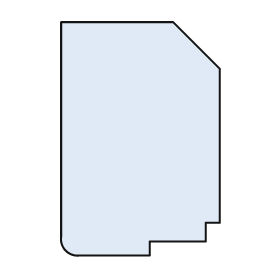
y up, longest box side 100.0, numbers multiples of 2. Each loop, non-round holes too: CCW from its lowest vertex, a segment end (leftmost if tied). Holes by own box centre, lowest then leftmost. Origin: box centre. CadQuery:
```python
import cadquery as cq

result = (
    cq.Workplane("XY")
    .moveTo(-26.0, -50.0)
    .lineTo(4.0, -50.0)
    .lineTo(4.0, -44.0)
    .lineTo(28.0, -44.0)
    .lineTo(28.0, -36.0)
    .lineTo(34.0, -36.0)
    .lineTo(34.0, 30.0)
    .lineTo(14.0, 50.0)
    .lineTo(-34.0, 50.0)
    .lineTo(-34.0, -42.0)
    .threePointArc((-32.0, -48.0), (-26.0, -50.0))
    .close()
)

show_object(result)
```